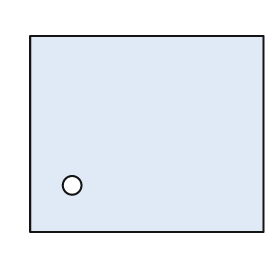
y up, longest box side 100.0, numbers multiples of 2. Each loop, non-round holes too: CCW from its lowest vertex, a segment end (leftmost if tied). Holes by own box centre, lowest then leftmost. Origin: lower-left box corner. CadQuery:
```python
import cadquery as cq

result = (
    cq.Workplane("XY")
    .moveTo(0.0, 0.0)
    .lineTo(100.0, 0.0)
    .lineTo(100.0, 84.0)
    .lineTo(0.0, 84.0)
    .close()
    .moveTo(18.0, 20.0)
    .circle(4.0)
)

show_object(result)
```